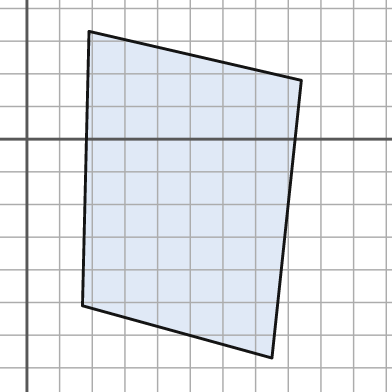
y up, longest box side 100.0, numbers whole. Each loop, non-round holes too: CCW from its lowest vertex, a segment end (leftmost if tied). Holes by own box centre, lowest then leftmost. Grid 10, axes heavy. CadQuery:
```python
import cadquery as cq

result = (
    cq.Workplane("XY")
    .moveTo(75.0, -67.0)
    .lineTo(84.0, 18.0)
    .lineTo(19.0, 33.0)
    .lineTo(17.0, -51.0)
    .close()
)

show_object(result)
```